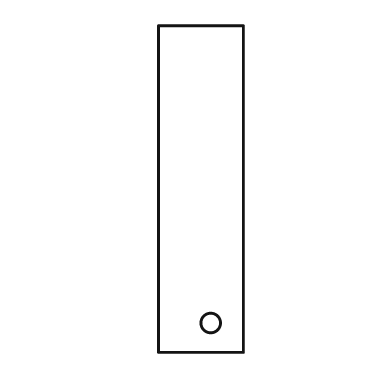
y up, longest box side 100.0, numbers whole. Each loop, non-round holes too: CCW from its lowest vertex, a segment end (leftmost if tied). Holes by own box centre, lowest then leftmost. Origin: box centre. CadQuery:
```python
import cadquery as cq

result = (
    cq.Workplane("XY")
    .moveTo(-13.0, -50.0)
    .lineTo(13.0, -50.0)
    .lineTo(13.0, 50.0)
    .lineTo(-13.0, 50.0)
    .close()
    .moveTo(3.0, -41.0)
    .circle(3.0)
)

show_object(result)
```